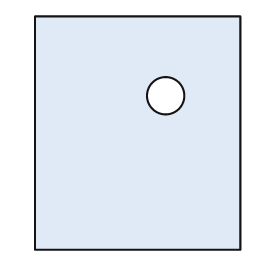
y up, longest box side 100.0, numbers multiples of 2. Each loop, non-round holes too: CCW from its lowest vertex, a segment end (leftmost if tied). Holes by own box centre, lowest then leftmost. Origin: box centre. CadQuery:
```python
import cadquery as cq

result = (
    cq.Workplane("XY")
    .moveTo(-44.0, -50.0)
    .lineTo(44.0, -50.0)
    .lineTo(44.0, 50.0)
    .lineTo(-44.0, 50.0)
    .close()
    .moveTo(12.0, 16.0)
    .circle(8.0)
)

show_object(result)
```